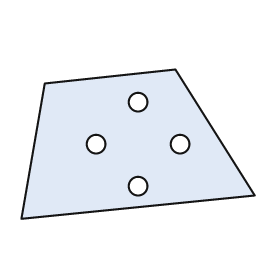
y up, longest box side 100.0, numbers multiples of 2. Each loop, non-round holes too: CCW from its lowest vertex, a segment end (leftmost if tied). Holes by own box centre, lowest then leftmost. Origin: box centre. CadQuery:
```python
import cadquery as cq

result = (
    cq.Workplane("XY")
    .moveTo(-50.0, -32.0)
    .lineTo(50.0, -22.0)
    .lineTo(16.0, 32.0)
    .lineTo(-40.0, 26.0)
    .close()
    .moveTo(0.0, -18.0)
    .circle(4.0)
    .moveTo(-18.0, 0.0)
    .circle(4.0)
    .moveTo(18.0, 0.0)
    .circle(4.0)
    .moveTo(0.0, 18.0)
    .circle(4.0)
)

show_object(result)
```